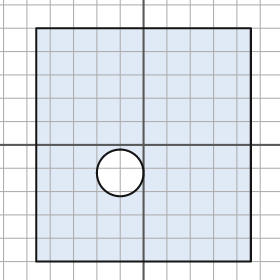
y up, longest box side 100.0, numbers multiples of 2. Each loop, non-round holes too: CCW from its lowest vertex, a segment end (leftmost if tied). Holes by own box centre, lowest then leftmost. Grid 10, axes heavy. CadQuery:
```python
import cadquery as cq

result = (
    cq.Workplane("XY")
    .moveTo(-46.0, -50.0)
    .lineTo(46.0, -50.0)
    .lineTo(46.0, 50.0)
    .lineTo(-46.0, 50.0)
    .close()
    .moveTo(-10.0, -12.0)
    .circle(10.0)
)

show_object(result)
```